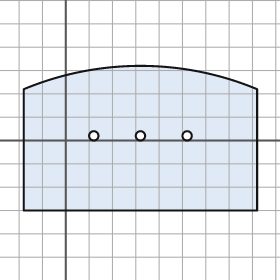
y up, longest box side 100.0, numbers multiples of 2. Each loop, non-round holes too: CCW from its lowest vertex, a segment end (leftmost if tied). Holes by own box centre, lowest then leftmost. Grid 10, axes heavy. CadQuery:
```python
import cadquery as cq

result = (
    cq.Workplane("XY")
    .moveTo(-18.0, -30.0)
    .lineTo(82.0, -30.0)
    .lineTo(82.0, 22.0)
    .threePointArc((32.0, 32.0), (-18.0, 22.0))
    .close()
    .moveTo(12.0, 2.0)
    .circle(2.0)
    .moveTo(32.0, 2.0)
    .circle(2.0)
    .moveTo(52.0, 2.0)
    .circle(2.0)
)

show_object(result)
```